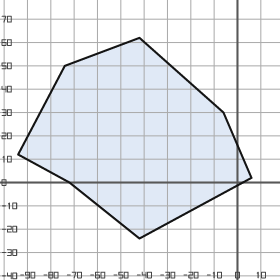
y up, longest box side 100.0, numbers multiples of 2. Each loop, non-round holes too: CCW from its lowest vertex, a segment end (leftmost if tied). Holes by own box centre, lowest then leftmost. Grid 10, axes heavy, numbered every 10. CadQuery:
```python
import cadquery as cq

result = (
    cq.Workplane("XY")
    .moveTo(-42.0, -24.0)
    .lineTo(6.0, 2.0)
    .lineTo(-6.0, 30.0)
    .lineTo(-42.0, 62.0)
    .lineTo(-74.0, 50.0)
    .lineTo(-94.0, 12.0)
    .lineTo(-72.0, 0.0)
    .close()
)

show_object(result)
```